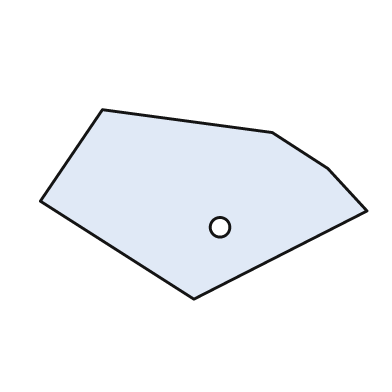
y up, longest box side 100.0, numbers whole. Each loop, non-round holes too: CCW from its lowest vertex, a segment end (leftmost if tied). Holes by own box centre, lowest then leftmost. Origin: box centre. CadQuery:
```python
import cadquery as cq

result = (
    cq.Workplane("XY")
    .moveTo(-3.0, -29.0)
    .lineTo(50.0, -2.0)
    .lineTo(38.0, 11.0)
    .lineTo(21.0, 22.0)
    .lineTo(-31.0, 29.0)
    .lineTo(-50.0, 1.0)
    .close()
    .moveTo(5.0, -7.0)
    .circle(3.0)
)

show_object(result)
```